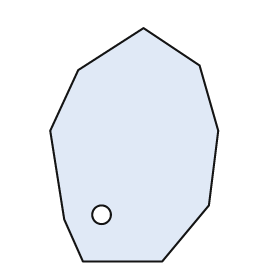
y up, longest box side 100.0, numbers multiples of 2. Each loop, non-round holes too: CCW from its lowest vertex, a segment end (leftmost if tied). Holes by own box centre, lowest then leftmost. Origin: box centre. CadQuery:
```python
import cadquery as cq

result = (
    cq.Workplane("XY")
    .moveTo(-22.0, -50.0)
    .lineTo(12.0, -50.0)
    .lineTo(32.0, -26.0)
    .lineTo(36.0, 6.0)
    .lineTo(28.0, 34.0)
    .lineTo(4.0, 50.0)
    .lineTo(-24.0, 32.0)
    .lineTo(-36.0, 6.0)
    .lineTo(-30.0, -32.0)
    .close()
    .moveTo(-14.0, -30.0)
    .circle(4.0)
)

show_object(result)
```